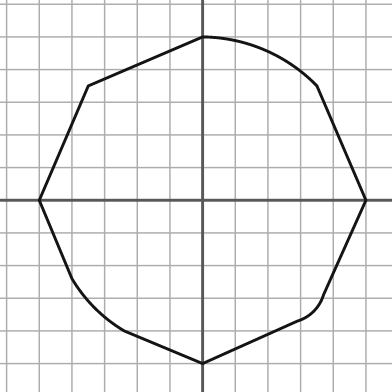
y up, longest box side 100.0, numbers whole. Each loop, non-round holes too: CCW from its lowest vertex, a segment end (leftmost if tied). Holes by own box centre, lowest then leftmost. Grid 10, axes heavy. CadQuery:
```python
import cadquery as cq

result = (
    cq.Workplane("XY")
    .moveTo(0.0, -50.0)
    .lineTo(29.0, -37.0)
    .threePointArc((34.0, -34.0), (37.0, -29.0))
    .lineTo(50.0, 0.0)
    .lineTo(35.0, 35.0)
    .threePointArc((19.0, 46.0), (0.0, 50.0))
    .lineTo(-35.0, 35.0)
    .lineTo(-50.0, 0.0)
    .lineTo(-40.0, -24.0)
    .threePointArc((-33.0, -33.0), (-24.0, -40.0))
    .close()
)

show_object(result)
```